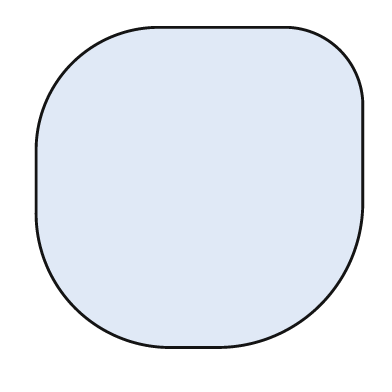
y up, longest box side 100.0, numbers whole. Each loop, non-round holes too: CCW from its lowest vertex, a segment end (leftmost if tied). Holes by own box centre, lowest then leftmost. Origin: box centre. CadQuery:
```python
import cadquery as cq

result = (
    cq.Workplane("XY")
    .moveTo(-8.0, -49.0)
    .lineTo(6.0, -49.0)
    .threePointArc((37.0, -36.0), (50.0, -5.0))
    .lineTo(50.0, 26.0)
    .threePointArc((43.0, 42.0), (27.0, 49.0))
    .lineTo(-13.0, 49.0)
    .threePointArc((-39.0, 38.0), (-50.0, 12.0))
    .lineTo(-50.0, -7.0)
    .threePointArc((-38.0, -37.0), (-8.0, -49.0))
    .close()
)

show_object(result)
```